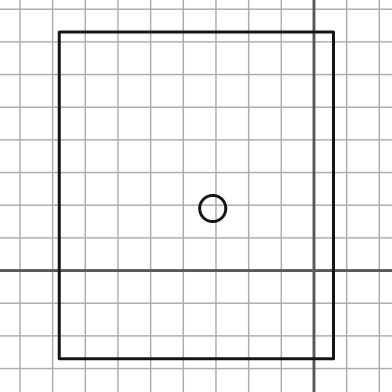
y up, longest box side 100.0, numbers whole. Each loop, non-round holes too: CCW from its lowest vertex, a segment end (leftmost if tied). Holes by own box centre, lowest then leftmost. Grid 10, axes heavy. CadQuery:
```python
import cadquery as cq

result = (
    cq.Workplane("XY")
    .moveTo(-78.0, -27.0)
    .lineTo(6.0, -27.0)
    .lineTo(6.0, 73.0)
    .lineTo(-78.0, 73.0)
    .close()
    .moveTo(-31.0, 19.0)
    .circle(4.0)
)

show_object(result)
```